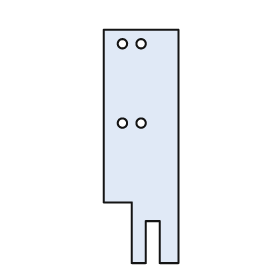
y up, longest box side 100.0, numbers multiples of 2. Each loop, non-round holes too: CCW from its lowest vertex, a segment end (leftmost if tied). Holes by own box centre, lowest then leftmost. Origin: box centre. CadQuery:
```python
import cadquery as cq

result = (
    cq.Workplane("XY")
    .moveTo(-4.0, -50.0)
    .lineTo(2.0, -50.0)
    .lineTo(2.0, -32.0)
    .lineTo(8.0, -32.0)
    .lineTo(8.0, -50.0)
    .lineTo(16.0, -50.0)
    .lineTo(16.0, 50.0)
    .lineTo(-16.0, 50.0)
    .lineTo(-16.0, -24.0)
    .lineTo(-4.0, -24.0)
    .close()
    .moveTo(-8.0, 10.0)
    .circle(2.0)
    .moveTo(0.0, 10.0)
    .circle(2.0)
    .moveTo(-8.0, 44.0)
    .circle(2.0)
    .moveTo(0.0, 44.0)
    .circle(2.0)
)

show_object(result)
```